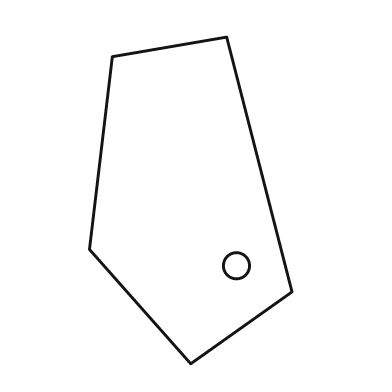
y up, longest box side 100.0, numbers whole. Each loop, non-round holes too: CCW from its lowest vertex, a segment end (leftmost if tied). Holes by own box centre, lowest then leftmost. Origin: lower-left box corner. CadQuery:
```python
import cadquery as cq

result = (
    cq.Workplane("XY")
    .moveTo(31.0, 0.0)
    .lineTo(62.0, 22.0)
    .lineTo(42.0, 100.0)
    .lineTo(7.0, 94.0)
    .lineTo(0.0, 35.0)
    .close()
    .moveTo(45.0, 30.0)
    .circle(4.0)
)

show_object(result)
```